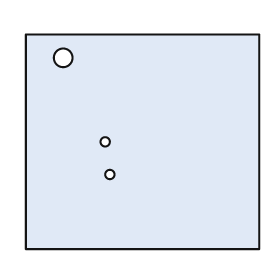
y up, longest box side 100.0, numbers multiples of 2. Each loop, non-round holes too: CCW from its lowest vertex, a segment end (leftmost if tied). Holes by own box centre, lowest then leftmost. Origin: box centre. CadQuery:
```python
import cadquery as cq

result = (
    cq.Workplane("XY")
    .moveTo(-50.0, -46.0)
    .lineTo(50.0, -46.0)
    .lineTo(50.0, 46.0)
    .lineTo(-50.0, 46.0)
    .close()
    .moveTo(-14.0, -14.0)
    .circle(2.0)
    .moveTo(-16.0, 0.0)
    .circle(2.0)
    .moveTo(-34.0, 36.0)
    .circle(4.0)
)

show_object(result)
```